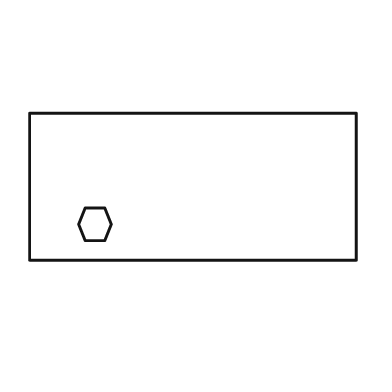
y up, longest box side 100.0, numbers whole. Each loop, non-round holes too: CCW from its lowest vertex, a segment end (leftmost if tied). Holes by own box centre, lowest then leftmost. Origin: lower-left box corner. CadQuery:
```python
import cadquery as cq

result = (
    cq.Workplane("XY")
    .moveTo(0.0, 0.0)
    .lineTo(100.0, 0.0)
    .lineTo(100.0, 45.0)
    .lineTo(0.0, 45.0)
    .close()
    .moveTo(17.0, 6.0)
    .lineTo(23.0, 6.0)
    .lineTo(25.0, 11.0)
    .lineTo(23.0, 16.0)
    .lineTo(17.0, 16.0)
    .lineTo(15.0, 11.0)
    .close()
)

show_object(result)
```